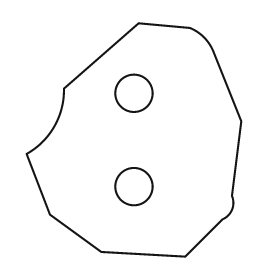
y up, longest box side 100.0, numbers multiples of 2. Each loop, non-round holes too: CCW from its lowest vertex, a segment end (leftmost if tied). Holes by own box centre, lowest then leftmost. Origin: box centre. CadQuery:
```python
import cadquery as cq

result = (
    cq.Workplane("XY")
    .moveTo(22.0, -50.0)
    .lineTo(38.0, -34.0)
    .threePointArc((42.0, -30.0), (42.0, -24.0))
    .lineTo(46.0, 8.0)
    .lineTo(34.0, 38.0)
    .threePointArc((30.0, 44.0), (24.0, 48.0))
    .lineTo(2.0, 50.0)
    .lineTo(-30.0, 22.0)
    .threePointArc((-34.0, 6.0), (-46.0, -6.0))
    .lineTo(-36.0, -32.0)
    .lineTo(-14.0, -48.0)
    .close()
    .moveTo(0.0, -20.0)
    .circle(8.0)
    .moveTo(0.0, 20.0)
    .circle(8.0)
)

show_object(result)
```